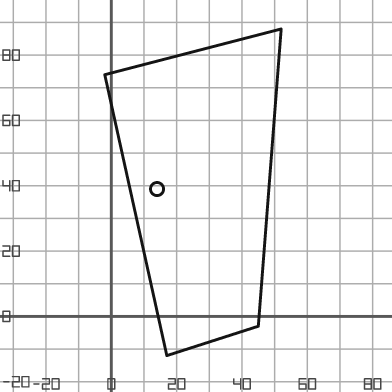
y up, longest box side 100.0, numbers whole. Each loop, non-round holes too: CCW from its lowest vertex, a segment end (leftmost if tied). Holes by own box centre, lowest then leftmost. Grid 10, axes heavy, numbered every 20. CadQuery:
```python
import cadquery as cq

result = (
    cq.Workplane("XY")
    .moveTo(17.0, -12.0)
    .lineTo(45.0, -3.0)
    .lineTo(52.0, 88.0)
    .lineTo(-2.0, 74.0)
    .close()
    .moveTo(14.0, 39.0)
    .circle(2.0)
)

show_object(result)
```